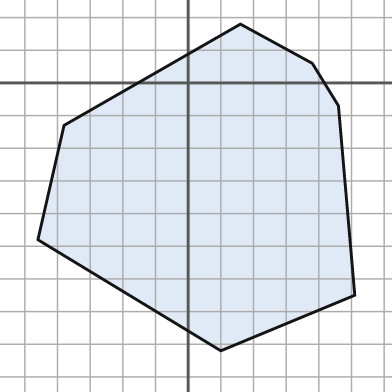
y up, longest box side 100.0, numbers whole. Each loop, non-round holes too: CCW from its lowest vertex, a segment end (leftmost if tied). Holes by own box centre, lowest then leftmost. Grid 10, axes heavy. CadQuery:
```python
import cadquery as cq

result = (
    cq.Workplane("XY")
    .moveTo(10.0, -82.0)
    .lineTo(51.0, -65.0)
    .lineTo(46.0, -7.0)
    .lineTo(38.0, 6.0)
    .lineTo(16.0, 18.0)
    .lineTo(-38.0, -13.0)
    .lineTo(-46.0, -48.0)
    .close()
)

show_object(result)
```